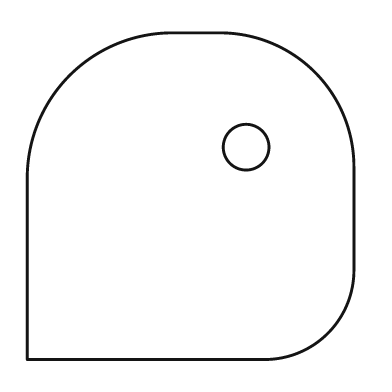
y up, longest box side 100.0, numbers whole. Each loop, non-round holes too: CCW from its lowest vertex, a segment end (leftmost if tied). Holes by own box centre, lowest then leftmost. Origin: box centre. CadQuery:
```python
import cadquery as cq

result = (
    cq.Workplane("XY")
    .moveTo(-50.0, -50.0)
    .lineTo(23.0, -50.0)
    .threePointArc((42.0, -42.0), (50.0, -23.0))
    .lineTo(50.0, 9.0)
    .threePointArc((38.0, 38.0), (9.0, 50.0))
    .lineTo(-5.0, 50.0)
    .threePointArc((-37.0, 37.0), (-50.0, 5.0))
    .close()
    .moveTo(17.0, 15.0)
    .circle(7.0)
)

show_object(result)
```